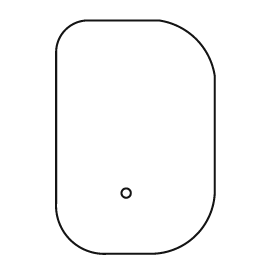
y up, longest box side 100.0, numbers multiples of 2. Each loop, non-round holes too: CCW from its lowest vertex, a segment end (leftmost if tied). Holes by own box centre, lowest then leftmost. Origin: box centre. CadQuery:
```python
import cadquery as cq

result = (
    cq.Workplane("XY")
    .moveTo(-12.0, -50.0)
    .lineTo(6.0, -50.0)
    .threePointArc((26.0, -42.0), (34.0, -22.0))
    .lineTo(34.0, 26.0)
    .threePointArc((26.0, 42.0), (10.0, 50.0))
    .lineTo(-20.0, 50.0)
    .threePointArc((-30.0, 46.0), (-34.0, 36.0))
    .lineTo(-34.0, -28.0)
    .threePointArc((-28.0, -44.0), (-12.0, -50.0))
    .close()
    .moveTo(-4.0, -24.0)
    .circle(2.0)
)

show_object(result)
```